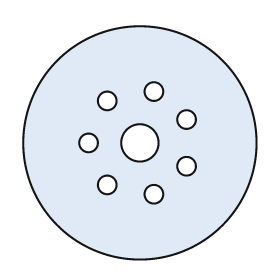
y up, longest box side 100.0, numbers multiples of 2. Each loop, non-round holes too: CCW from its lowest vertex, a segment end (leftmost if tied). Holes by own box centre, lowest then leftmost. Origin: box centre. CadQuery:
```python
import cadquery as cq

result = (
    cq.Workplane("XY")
    .moveTo(0.0, 0.0)
    .circle(50.0)
    .moveTo(6.0, -22.0)
    .circle(4.0)
    .moveTo(-14.0, -18.0)
    .circle(4.0)
    .moveTo(20.0, -10.0)
    .circle(4.0)
    .moveTo(-22.0, 0.0)
    .circle(4.0)
    .moveTo(0.0, 0.0)
    .circle(8.0)
    .moveTo(20.0, 10.0)
    .circle(4.0)
    .moveTo(-14.0, 18.0)
    .circle(4.0)
    .moveTo(6.0, 22.0)
    .circle(4.0)
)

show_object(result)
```